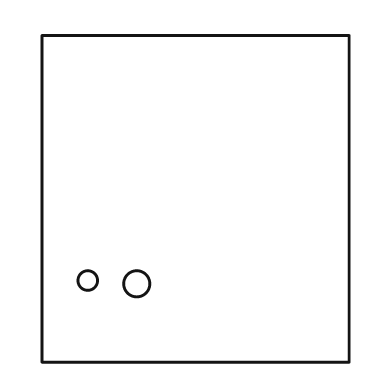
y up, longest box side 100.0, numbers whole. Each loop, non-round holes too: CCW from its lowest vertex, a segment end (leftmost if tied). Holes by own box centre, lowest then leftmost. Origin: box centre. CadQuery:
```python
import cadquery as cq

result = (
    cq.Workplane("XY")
    .moveTo(-47.0, -50.0)
    .lineTo(47.0, -50.0)
    .lineTo(47.0, 50.0)
    .lineTo(-47.0, 50.0)
    .close()
    .moveTo(-18.0, -26.0)
    .circle(4.0)
    .moveTo(-33.0, -25.0)
    .circle(3.0)
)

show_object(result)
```